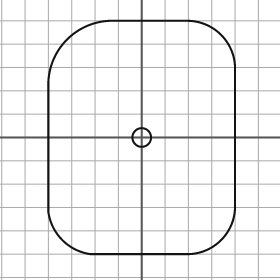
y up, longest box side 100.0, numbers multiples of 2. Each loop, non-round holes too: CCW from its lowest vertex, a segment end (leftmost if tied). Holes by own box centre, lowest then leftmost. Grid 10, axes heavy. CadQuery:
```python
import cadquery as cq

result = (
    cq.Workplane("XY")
    .moveTo(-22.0, -50.0)
    .lineTo(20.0, -50.0)
    .threePointArc((34.0, -44.0), (40.0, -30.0))
    .lineTo(40.0, 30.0)
    .threePointArc((34.0, 44.0), (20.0, 50.0))
    .lineTo(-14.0, 50.0)
    .threePointArc((-32.0, 42.0), (-40.0, 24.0))
    .lineTo(-40.0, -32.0)
    .threePointArc((-34.0, -44.0), (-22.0, -50.0))
    .close()
    .moveTo(0.0, 0.0)
    .circle(4.0)
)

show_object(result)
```